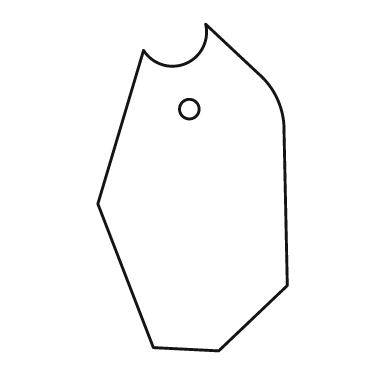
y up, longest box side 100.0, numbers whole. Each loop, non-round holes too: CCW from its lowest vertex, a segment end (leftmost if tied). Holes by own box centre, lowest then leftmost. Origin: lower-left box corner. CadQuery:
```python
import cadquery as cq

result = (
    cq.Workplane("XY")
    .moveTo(37.0, 0.0)
    .lineTo(58.0, 20.0)
    .lineTo(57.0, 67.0)
    .threePointArc((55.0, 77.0), (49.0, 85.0))
    .lineTo(33.0, 100.0)
    .threePointArc((27.0, 88.0), (14.0, 92.0))
    .lineTo(0.0, 45.0)
    .lineTo(17.0, 1.0)
    .close()
    .moveTo(28.0, 74.0)
    .circle(3.0)
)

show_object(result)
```